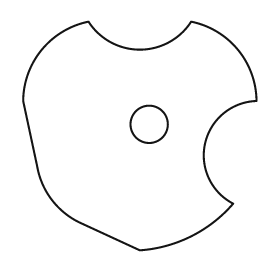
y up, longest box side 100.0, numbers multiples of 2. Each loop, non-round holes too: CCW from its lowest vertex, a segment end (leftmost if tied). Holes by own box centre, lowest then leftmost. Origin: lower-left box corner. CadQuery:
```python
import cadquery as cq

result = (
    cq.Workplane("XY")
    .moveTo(50.0, 0.0)
    .threePointArc((72.0, 6.0), (90.0, 20.0))
    .threePointArc((78.0, 46.0), (100.0, 64.0))
    .threePointArc((92.0, 86.0), (72.0, 98.0))
    .threePointArc((50.0, 86.0), (28.0, 98.0))
    .threePointArc((8.0, 86.0), (0.0, 64.0))
    .lineTo(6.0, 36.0)
    .threePointArc((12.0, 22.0), (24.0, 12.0))
    .close()
    .moveTo(54.0, 54.0)
    .circle(8.0)
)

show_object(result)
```